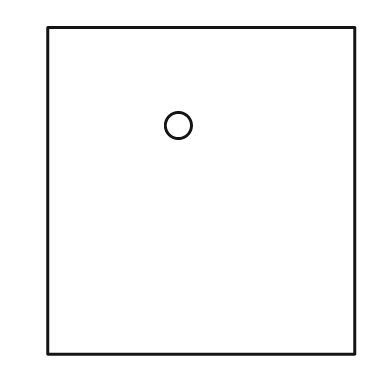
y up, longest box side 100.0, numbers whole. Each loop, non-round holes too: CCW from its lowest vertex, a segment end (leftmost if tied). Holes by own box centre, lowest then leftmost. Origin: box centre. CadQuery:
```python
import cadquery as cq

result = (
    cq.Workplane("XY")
    .moveTo(-47.0, -50.0)
    .lineTo(47.0, -50.0)
    .lineTo(47.0, 50.0)
    .lineTo(-47.0, 50.0)
    .close()
    .moveTo(-7.0, 20.0)
    .circle(4.0)
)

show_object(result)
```